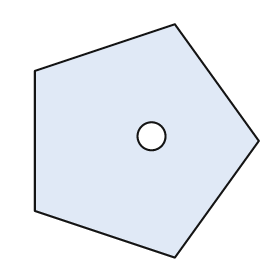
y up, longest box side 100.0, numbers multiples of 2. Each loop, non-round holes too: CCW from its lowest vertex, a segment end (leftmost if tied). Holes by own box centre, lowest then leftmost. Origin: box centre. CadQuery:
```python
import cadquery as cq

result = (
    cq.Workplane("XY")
    .moveTo(12.0, -50.0)
    .lineTo(48.0, 0.0)
    .lineTo(12.0, 50.0)
    .lineTo(-48.0, 30.0)
    .lineTo(-48.0, -30.0)
    .close()
    .moveTo(2.0, 2.0)
    .circle(6.0)
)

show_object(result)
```